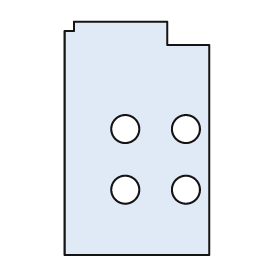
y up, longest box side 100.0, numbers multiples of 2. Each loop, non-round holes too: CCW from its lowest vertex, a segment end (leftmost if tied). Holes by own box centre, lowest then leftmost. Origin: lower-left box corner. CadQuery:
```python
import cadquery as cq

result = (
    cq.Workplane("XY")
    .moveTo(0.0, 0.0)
    .lineTo(62.0, 0.0)
    .lineTo(62.0, 90.0)
    .lineTo(44.0, 90.0)
    .lineTo(44.0, 100.0)
    .lineTo(4.0, 100.0)
    .lineTo(4.0, 96.0)
    .lineTo(0.0, 96.0)
    .close()
    .moveTo(26.0, 28.0)
    .circle(6.0)
    .moveTo(52.0, 28.0)
    .circle(6.0)
    .moveTo(26.0, 54.0)
    .circle(6.0)
    .moveTo(52.0, 54.0)
    .circle(6.0)
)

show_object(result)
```